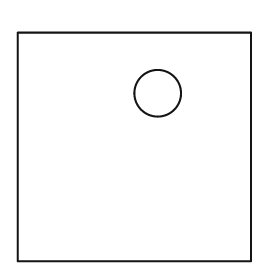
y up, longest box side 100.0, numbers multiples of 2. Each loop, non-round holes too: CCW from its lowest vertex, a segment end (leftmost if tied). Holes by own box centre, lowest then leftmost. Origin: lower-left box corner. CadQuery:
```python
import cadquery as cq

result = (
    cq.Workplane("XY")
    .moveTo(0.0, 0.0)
    .lineTo(100.0, 0.0)
    .lineTo(100.0, 98.0)
    .lineTo(0.0, 98.0)
    .close()
    .moveTo(60.0, 72.0)
    .circle(10.0)
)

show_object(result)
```